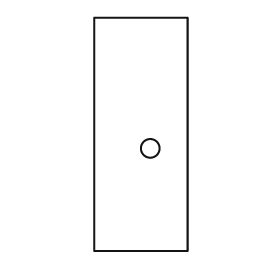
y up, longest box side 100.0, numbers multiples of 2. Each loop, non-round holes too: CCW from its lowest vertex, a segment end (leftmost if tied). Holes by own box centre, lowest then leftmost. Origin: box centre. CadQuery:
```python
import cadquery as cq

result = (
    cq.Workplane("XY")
    .moveTo(-20.0, -50.0)
    .lineTo(20.0, -50.0)
    .lineTo(20.0, 50.0)
    .lineTo(-20.0, 50.0)
    .close()
    .moveTo(4.0, -6.0)
    .circle(4.0)
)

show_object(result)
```